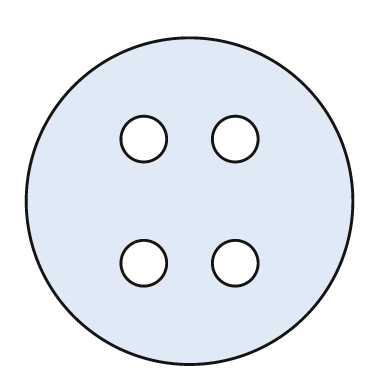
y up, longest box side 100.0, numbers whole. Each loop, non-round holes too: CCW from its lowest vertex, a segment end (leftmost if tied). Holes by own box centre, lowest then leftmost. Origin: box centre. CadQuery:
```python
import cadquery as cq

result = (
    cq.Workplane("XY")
    .moveTo(0.0, 0.0)
    .circle(50.0)
    .moveTo(-14.0, -19.0)
    .circle(7.0)
    .moveTo(14.0, -19.0)
    .circle(7.0)
    .moveTo(-14.0, 19.0)
    .circle(7.0)
    .moveTo(14.0, 19.0)
    .circle(7.0)
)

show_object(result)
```